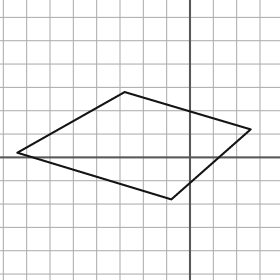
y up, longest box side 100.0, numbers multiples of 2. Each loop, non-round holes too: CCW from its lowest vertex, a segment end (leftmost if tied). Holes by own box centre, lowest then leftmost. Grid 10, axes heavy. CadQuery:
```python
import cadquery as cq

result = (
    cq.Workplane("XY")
    .moveTo(-8.0, -18.0)
    .lineTo(26.0, 12.0)
    .lineTo(-28.0, 28.0)
    .lineTo(-74.0, 2.0)
    .close()
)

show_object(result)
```